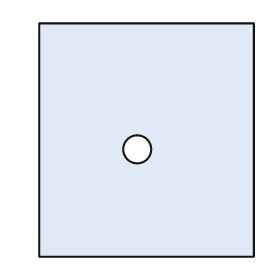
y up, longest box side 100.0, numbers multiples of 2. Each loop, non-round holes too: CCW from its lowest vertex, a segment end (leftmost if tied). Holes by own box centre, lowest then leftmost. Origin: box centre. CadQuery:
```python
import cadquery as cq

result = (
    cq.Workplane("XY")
    .moveTo(-46.0, -50.0)
    .lineTo(46.0, -50.0)
    .lineTo(46.0, 50.0)
    .lineTo(-46.0, 50.0)
    .close()
    .moveTo(-4.0, -4.0)
    .circle(6.0)
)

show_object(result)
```